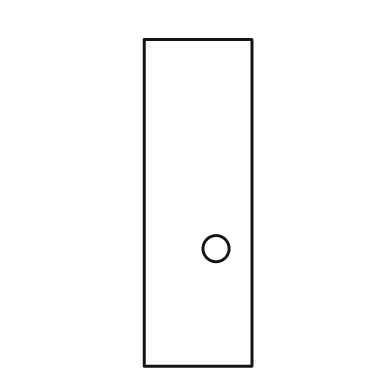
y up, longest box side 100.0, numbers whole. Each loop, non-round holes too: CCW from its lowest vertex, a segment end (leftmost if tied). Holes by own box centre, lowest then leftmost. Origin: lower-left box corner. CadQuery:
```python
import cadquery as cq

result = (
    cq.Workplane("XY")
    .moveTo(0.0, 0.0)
    .lineTo(33.0, 0.0)
    .lineTo(33.0, 100.0)
    .lineTo(0.0, 100.0)
    .close()
    .moveTo(22.0, 36.0)
    .circle(4.0)
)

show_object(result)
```